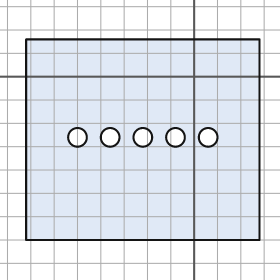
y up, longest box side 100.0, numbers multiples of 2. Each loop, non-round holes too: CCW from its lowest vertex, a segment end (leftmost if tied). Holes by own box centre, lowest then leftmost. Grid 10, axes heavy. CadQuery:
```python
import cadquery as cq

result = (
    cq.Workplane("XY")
    .moveTo(-72.0, -70.0)
    .lineTo(28.0, -70.0)
    .lineTo(28.0, 16.0)
    .lineTo(-72.0, 16.0)
    .close()
    .moveTo(-50.0, -26.0)
    .circle(4.0)
    .moveTo(-36.0, -26.0)
    .circle(4.0)
    .moveTo(-22.0, -26.0)
    .circle(4.0)
    .moveTo(-8.0, -26.0)
    .circle(4.0)
    .moveTo(6.0, -26.0)
    .circle(4.0)
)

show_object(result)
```